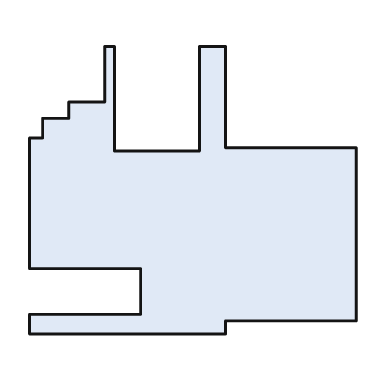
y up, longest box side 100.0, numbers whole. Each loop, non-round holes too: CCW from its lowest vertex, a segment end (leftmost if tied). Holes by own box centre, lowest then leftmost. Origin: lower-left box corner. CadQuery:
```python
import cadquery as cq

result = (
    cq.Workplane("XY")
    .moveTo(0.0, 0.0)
    .lineTo(60.0, 0.0)
    .lineTo(60.0, 4.0)
    .lineTo(100.0, 4.0)
    .lineTo(100.0, 57.0)
    .lineTo(60.0, 57.0)
    .lineTo(60.0, 88.0)
    .lineTo(52.0, 88.0)
    .lineTo(52.0, 56.0)
    .lineTo(26.0, 56.0)
    .lineTo(26.0, 88.0)
    .lineTo(23.0, 88.0)
    .lineTo(23.0, 71.0)
    .lineTo(12.0, 71.0)
    .lineTo(12.0, 66.0)
    .lineTo(4.0, 66.0)
    .lineTo(4.0, 60.0)
    .lineTo(0.0, 60.0)
    .lineTo(0.0, 20.0)
    .lineTo(34.0, 20.0)
    .lineTo(34.0, 6.0)
    .lineTo(0.0, 6.0)
    .close()
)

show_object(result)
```